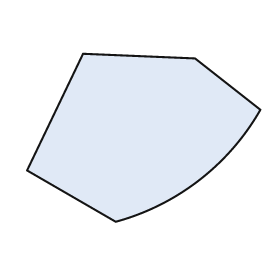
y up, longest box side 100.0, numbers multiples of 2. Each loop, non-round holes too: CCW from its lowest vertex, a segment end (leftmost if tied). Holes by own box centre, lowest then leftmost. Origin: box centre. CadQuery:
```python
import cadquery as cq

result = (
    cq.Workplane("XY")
    .moveTo(-12.0, -36.0)
    .threePointArc((24.0, -18.0), (50.0, 12.0))
    .lineTo(22.0, 34.0)
    .lineTo(-26.0, 36.0)
    .lineTo(-50.0, -14.0)
    .close()
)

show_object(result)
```